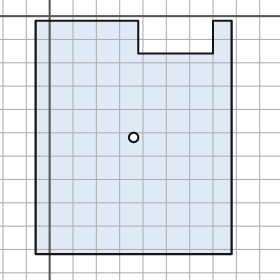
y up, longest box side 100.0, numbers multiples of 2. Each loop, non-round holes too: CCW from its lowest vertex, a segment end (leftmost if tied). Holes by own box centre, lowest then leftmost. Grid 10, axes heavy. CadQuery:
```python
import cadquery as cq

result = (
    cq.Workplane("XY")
    .moveTo(-6.0, -102.0)
    .lineTo(78.0, -102.0)
    .lineTo(78.0, -2.0)
    .lineTo(70.0, -2.0)
    .lineTo(70.0, -16.0)
    .lineTo(38.0, -16.0)
    .lineTo(38.0, -2.0)
    .lineTo(-6.0, -2.0)
    .close()
    .moveTo(36.0, -52.0)
    .circle(2.0)
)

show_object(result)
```